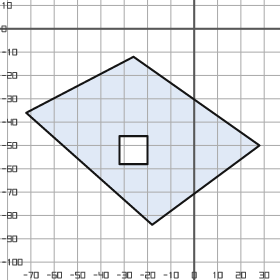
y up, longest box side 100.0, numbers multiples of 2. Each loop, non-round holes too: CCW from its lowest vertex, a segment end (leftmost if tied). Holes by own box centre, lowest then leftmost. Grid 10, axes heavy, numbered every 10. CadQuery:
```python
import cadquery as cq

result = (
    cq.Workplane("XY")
    .moveTo(-18.0, -84.0)
    .lineTo(28.0, -50.0)
    .lineTo(-26.0, -12.0)
    .lineTo(-72.0, -36.0)
    .close()
    .moveTo(-32.0, -58.0)
    .lineTo(-20.0, -58.0)
    .lineTo(-20.0, -46.0)
    .lineTo(-32.0, -46.0)
    .close()
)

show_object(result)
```